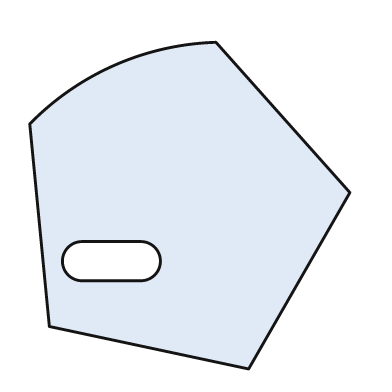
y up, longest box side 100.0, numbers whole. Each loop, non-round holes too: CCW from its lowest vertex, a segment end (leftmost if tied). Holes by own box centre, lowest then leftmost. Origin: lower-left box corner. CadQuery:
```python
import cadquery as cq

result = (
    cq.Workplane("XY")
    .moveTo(67.0, 0.0)
    .lineTo(98.0, 54.0)
    .lineTo(57.0, 100.0)
    .threePointArc((26.0, 93.0), (0.0, 75.0))
    .lineTo(6.0, 13.0)
    .close()
    .moveTo(16.0, 27.0)
    .lineTo(34.0, 27.0)
    .threePointArc((40.0, 33.0), (34.0, 39.0))
    .lineTo(16.0, 39.0)
    .threePointArc((10.0, 33.0), (16.0, 27.0))
    .close()
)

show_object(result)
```